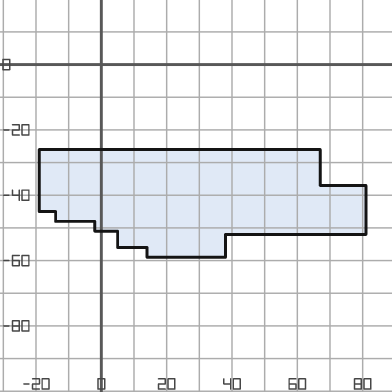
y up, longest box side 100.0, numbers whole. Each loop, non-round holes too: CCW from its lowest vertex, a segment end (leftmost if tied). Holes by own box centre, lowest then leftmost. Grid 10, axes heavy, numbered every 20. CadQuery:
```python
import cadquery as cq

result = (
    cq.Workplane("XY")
    .moveTo(14.0, -59.0)
    .lineTo(38.0, -59.0)
    .lineTo(38.0, -52.0)
    .lineTo(81.0, -52.0)
    .lineTo(81.0, -37.0)
    .lineTo(67.0, -37.0)
    .lineTo(67.0, -26.0)
    .lineTo(-19.0, -26.0)
    .lineTo(-19.0, -45.0)
    .lineTo(-14.0, -45.0)
    .lineTo(-14.0, -48.0)
    .lineTo(-2.0, -48.0)
    .lineTo(-2.0, -51.0)
    .lineTo(5.0, -51.0)
    .lineTo(5.0, -56.0)
    .lineTo(14.0, -56.0)
    .close()
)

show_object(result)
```